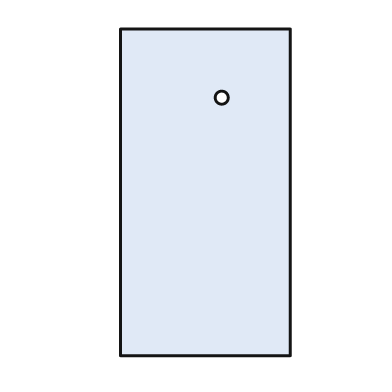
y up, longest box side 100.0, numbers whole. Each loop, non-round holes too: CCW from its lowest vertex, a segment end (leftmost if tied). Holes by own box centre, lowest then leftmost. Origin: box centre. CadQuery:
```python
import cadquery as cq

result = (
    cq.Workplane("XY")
    .moveTo(-26.0, -50.0)
    .lineTo(26.0, -50.0)
    .lineTo(26.0, 50.0)
    .lineTo(-26.0, 50.0)
    .close()
    .moveTo(5.0, 29.0)
    .circle(2.0)
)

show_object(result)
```